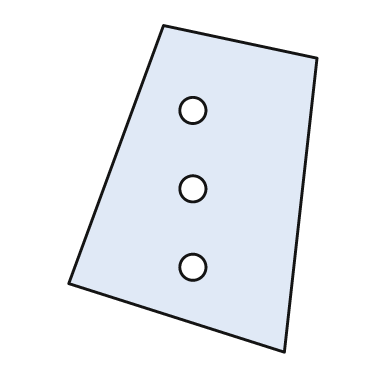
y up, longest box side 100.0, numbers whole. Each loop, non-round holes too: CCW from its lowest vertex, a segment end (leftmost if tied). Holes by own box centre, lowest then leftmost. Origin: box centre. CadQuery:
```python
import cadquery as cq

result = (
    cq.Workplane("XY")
    .moveTo(28.0, -50.0)
    .lineTo(38.0, 40.0)
    .lineTo(-9.0, 50.0)
    .lineTo(-38.0, -29.0)
    .close()
    .moveTo(0.0, -24.0)
    .circle(4.0)
    .moveTo(0.0, 0.0)
    .circle(4.0)
    .moveTo(0.0, 24.0)
    .circle(4.0)
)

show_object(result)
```